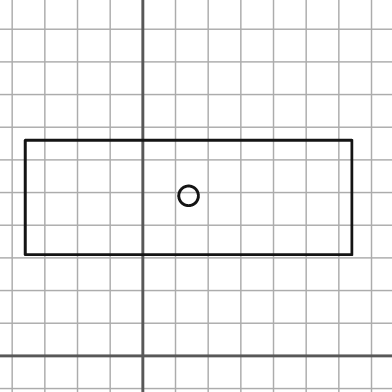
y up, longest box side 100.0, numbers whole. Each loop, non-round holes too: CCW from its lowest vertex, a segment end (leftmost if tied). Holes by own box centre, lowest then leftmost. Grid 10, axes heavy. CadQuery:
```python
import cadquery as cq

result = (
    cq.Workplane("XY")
    .moveTo(-36.0, 31.0)
    .lineTo(64.0, 31.0)
    .lineTo(64.0, 66.0)
    .lineTo(-36.0, 66.0)
    .close()
    .moveTo(14.0, 49.0)
    .circle(3.0)
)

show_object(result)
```